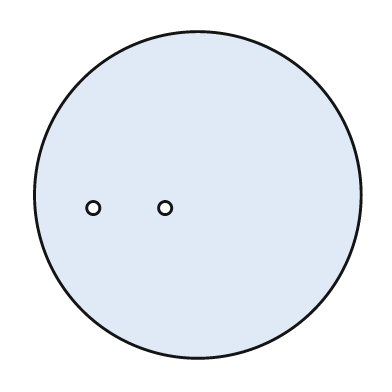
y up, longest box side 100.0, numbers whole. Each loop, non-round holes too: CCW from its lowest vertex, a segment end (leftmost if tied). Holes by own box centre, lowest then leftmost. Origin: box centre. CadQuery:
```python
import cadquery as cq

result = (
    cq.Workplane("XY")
    .moveTo(0.0, 0.0)
    .circle(50.0)
    .moveTo(-32.0, -4.0)
    .circle(2.0)
    .moveTo(-10.0, -4.0)
    .circle(2.0)
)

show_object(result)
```